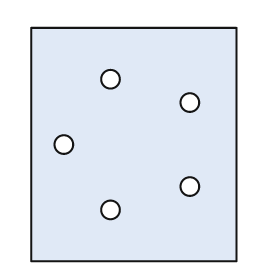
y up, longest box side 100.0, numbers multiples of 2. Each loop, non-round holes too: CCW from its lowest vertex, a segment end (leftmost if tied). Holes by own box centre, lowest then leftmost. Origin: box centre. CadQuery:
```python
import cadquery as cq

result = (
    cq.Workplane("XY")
    .moveTo(-44.0, -50.0)
    .lineTo(44.0, -50.0)
    .lineTo(44.0, 50.0)
    .lineTo(-44.0, 50.0)
    .close()
    .moveTo(-10.0, -28.0)
    .circle(4.0)
    .moveTo(24.0, -18.0)
    .circle(4.0)
    .moveTo(-30.0, 0.0)
    .circle(4.0)
    .moveTo(24.0, 18.0)
    .circle(4.0)
    .moveTo(-10.0, 28.0)
    .circle(4.0)
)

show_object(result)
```